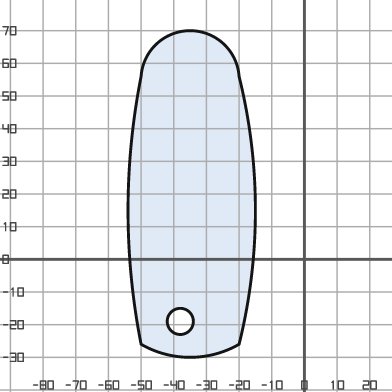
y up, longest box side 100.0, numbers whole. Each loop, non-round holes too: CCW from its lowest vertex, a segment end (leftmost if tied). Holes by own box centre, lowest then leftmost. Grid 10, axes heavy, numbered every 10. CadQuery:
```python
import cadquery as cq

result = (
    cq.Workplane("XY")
    .moveTo(-50.0, -26.0)
    .threePointArc((-35.0, -30.0), (-20.0, -26.0))
    .threePointArc((-15.0, 15.0), (-20.0, 56.0))
    .threePointArc((-35.0, 70.0), (-50.0, 56.0))
    .threePointArc((-54.0, 15.0), (-50.0, -26.0))
    .close()
    .moveTo(-38.0, -19.0)
    .circle(4.0)
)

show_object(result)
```